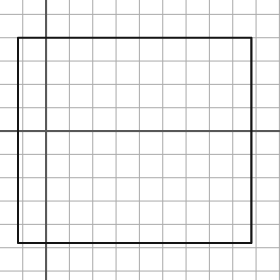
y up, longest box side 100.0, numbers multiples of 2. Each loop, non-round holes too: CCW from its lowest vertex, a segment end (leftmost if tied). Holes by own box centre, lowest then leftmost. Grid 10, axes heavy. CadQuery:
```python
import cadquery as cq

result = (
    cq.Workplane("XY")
    .moveTo(-12.0, -48.0)
    .lineTo(88.0, -48.0)
    .lineTo(88.0, 40.0)
    .lineTo(-12.0, 40.0)
    .close()
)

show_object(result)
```